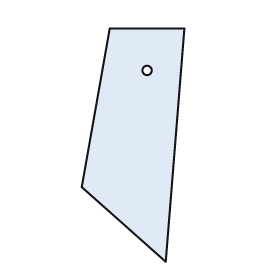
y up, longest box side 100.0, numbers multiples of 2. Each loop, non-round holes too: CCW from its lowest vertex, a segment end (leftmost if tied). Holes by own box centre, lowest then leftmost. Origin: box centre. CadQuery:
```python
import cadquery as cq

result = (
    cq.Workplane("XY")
    .moveTo(14.0, -50.0)
    .lineTo(22.0, 50.0)
    .lineTo(-10.0, 50.0)
    .lineTo(-22.0, -18.0)
    .close()
    .moveTo(6.0, 32.0)
    .circle(2.0)
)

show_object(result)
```